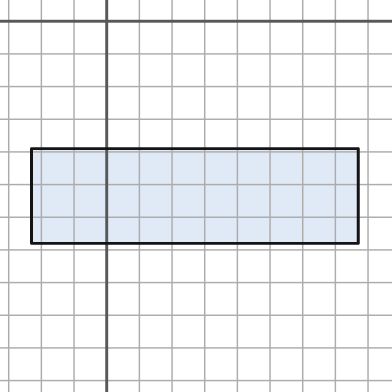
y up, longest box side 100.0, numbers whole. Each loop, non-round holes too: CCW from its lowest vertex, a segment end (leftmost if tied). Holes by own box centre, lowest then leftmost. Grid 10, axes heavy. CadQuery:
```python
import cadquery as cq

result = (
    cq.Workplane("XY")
    .moveTo(-23.0, -68.0)
    .lineTo(77.0, -68.0)
    .lineTo(77.0, -39.0)
    .lineTo(-23.0, -39.0)
    .close()
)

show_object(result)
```